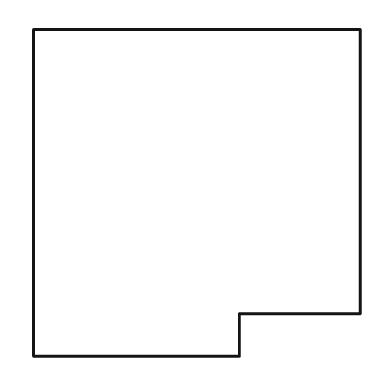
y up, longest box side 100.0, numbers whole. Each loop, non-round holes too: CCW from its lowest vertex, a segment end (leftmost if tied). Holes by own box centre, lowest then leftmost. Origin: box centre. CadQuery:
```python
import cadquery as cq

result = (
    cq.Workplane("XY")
    .moveTo(-50.0, -50.0)
    .lineTo(13.0, -50.0)
    .lineTo(13.0, -37.0)
    .lineTo(50.0, -37.0)
    .lineTo(50.0, 50.0)
    .lineTo(-50.0, 50.0)
    .close()
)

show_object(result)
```